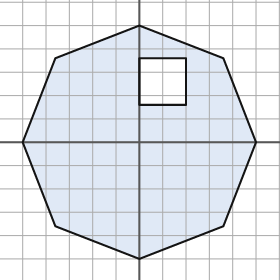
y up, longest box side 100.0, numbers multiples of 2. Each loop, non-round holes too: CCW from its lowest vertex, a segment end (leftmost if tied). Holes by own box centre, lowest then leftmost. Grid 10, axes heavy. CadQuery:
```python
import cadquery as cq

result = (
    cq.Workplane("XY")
    .moveTo(0.0, -50.0)
    .lineTo(36.0, -36.0)
    .lineTo(50.0, 0.0)
    .lineTo(36.0, 36.0)
    .lineTo(0.0, 50.0)
    .lineTo(-36.0, 36.0)
    .lineTo(-50.0, 0.0)
    .lineTo(-36.0, -36.0)
    .close()
    .moveTo(0.0, 16.0)
    .lineTo(20.0, 16.0)
    .lineTo(20.0, 36.0)
    .lineTo(0.0, 36.0)
    .close()
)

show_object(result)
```